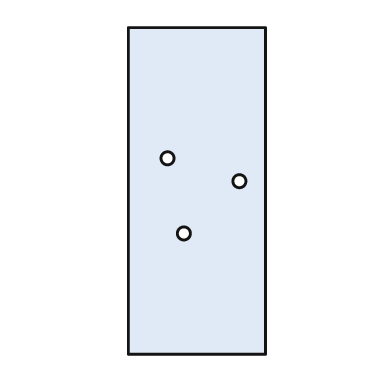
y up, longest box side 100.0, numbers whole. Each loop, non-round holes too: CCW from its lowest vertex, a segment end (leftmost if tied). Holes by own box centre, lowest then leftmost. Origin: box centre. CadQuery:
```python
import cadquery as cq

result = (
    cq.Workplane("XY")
    .moveTo(-21.0, -50.0)
    .lineTo(21.0, -50.0)
    .lineTo(21.0, 50.0)
    .lineTo(-21.0, 50.0)
    .close()
    .moveTo(-4.0, -13.0)
    .circle(2.0)
    .moveTo(13.0, 3.0)
    .circle(2.0)
    .moveTo(-9.0, 10.0)
    .circle(2.0)
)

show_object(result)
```